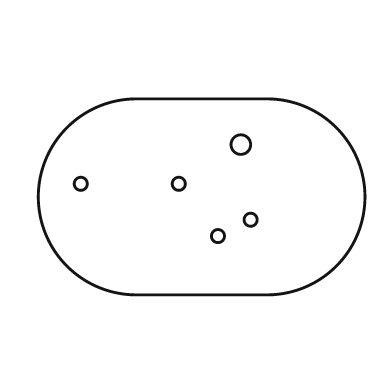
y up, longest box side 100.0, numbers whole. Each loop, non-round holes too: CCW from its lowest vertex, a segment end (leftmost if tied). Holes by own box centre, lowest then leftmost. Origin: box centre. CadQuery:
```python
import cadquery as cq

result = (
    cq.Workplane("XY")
    .moveTo(-20.0, -30.0)
    .lineTo(20.0, -30.0)
    .threePointArc((50.0, 0.0), (20.0, 30.0))
    .lineTo(-20.0, 30.0)
    .threePointArc((-50.0, 0.0), (-20.0, -30.0))
    .close()
    .moveTo(5.0, -12.0)
    .circle(2.0)
    .moveTo(15.0, -7.0)
    .circle(2.0)
    .moveTo(-37.0, 4.0)
    .circle(2.0)
    .moveTo(-7.0, 4.0)
    .circle(2.0)
    .moveTo(12.0, 16.0)
    .circle(3.0)
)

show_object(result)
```